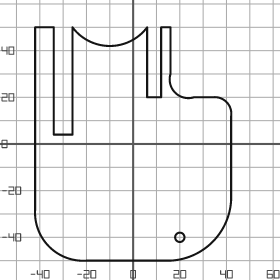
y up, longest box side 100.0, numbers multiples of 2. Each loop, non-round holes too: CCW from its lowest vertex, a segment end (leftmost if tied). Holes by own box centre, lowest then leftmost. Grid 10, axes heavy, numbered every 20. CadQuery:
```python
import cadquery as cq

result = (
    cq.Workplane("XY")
    .moveTo(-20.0, -50.0)
    .lineTo(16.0, -50.0)
    .threePointArc((34.0, -42.0), (42.0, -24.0))
    .lineTo(42.0, 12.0)
    .threePointArc((40.0, 18.0), (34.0, 20.0))
    .lineTo(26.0, 20.0)
    .threePointArc((18.0, 22.0), (16.0, 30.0))
    .lineTo(16.0, 50.0)
    .lineTo(12.0, 50.0)
    .lineTo(12.0, 20.0)
    .lineTo(6.0, 20.0)
    .lineTo(6.0, 50.0)
    .threePointArc((-10.0, 42.0), (-26.0, 50.0))
    .lineTo(-26.0, 4.0)
    .lineTo(-34.0, 4.0)
    .lineTo(-34.0, 50.0)
    .lineTo(-42.0, 50.0)
    .lineTo(-42.0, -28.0)
    .threePointArc((-36.0, -44.0), (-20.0, -50.0))
    .close()
    .moveTo(20.0, -40.0)
    .circle(2.0)
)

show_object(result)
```